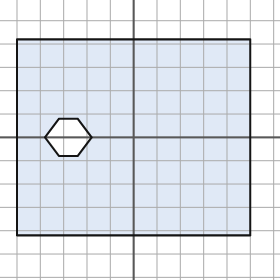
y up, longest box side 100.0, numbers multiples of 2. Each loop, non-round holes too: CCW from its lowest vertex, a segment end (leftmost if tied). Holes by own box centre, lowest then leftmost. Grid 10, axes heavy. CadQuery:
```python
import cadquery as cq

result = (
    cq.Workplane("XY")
    .moveTo(-50.0, -42.0)
    .lineTo(50.0, -42.0)
    .lineTo(50.0, 42.0)
    .lineTo(-50.0, 42.0)
    .close()
    .moveTo(-32.0, -8.0)
    .lineTo(-24.0, -8.0)
    .lineTo(-18.0, 0.0)
    .lineTo(-24.0, 8.0)
    .lineTo(-32.0, 8.0)
    .lineTo(-38.0, 0.0)
    .close()
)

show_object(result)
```